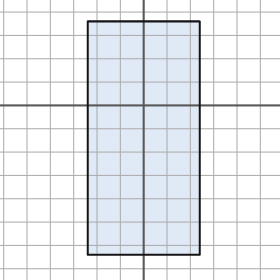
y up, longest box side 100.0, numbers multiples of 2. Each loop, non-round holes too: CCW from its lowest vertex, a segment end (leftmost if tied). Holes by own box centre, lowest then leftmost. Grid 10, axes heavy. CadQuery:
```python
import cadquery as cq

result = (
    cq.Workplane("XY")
    .moveTo(-24.0, -64.0)
    .lineTo(24.0, -64.0)
    .lineTo(24.0, 36.0)
    .lineTo(-24.0, 36.0)
    .close()
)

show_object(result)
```